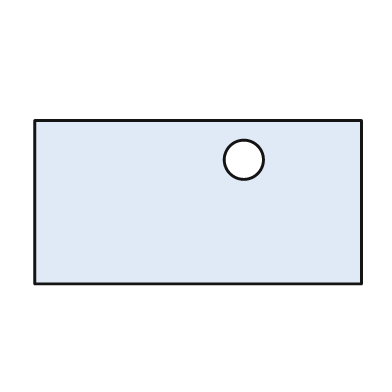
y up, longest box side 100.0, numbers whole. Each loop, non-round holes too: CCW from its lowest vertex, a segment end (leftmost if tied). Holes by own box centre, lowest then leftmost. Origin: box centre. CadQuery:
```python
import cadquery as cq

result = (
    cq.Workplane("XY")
    .moveTo(-50.0, -25.0)
    .lineTo(50.0, -25.0)
    .lineTo(50.0, 25.0)
    .lineTo(-50.0, 25.0)
    .close()
    .moveTo(14.0, 13.0)
    .circle(6.0)
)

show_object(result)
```